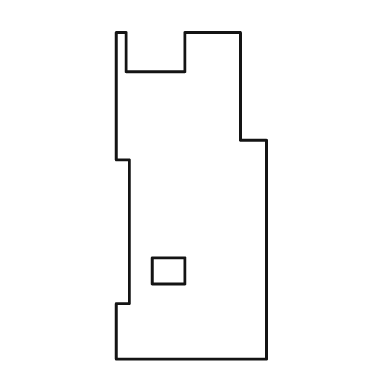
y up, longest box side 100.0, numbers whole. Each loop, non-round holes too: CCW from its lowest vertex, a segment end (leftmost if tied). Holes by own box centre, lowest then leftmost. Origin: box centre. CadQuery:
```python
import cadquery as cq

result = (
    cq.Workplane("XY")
    .moveTo(-23.0, -50.0)
    .lineTo(23.0, -50.0)
    .lineTo(23.0, 17.0)
    .lineTo(15.0, 17.0)
    .lineTo(15.0, 50.0)
    .lineTo(-2.0, 50.0)
    .lineTo(-2.0, 38.0)
    .lineTo(-20.0, 38.0)
    .lineTo(-20.0, 50.0)
    .lineTo(-23.0, 50.0)
    .lineTo(-23.0, 11.0)
    .lineTo(-19.0, 11.0)
    .lineTo(-19.0, -33.0)
    .lineTo(-23.0, -33.0)
    .close()
    .moveTo(-12.0, -27.0)
    .lineTo(-2.0, -27.0)
    .lineTo(-2.0, -19.0)
    .lineTo(-12.0, -19.0)
    .close()
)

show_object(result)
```